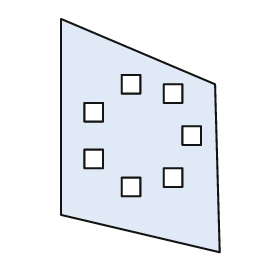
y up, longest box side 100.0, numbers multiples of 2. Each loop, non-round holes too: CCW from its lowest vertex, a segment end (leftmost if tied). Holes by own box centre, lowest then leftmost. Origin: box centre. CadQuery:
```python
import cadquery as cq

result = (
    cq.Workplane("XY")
    .moveTo(34.0, -50.0)
    .lineTo(32.0, 22.0)
    .lineTo(-34.0, 50.0)
    .lineTo(-34.0, -34.0)
    .close()
    .moveTo(-8.0, -26.0)
    .lineTo(0.0, -26.0)
    .lineTo(0.0, -18.0)
    .lineTo(-8.0, -18.0)
    .close()
    .moveTo(10.0, -22.0)
    .lineTo(18.0, -22.0)
    .lineTo(18.0, -14.0)
    .lineTo(10.0, -14.0)
    .close()
    .moveTo(-24.0, -14.0)
    .lineTo(-16.0, -14.0)
    .lineTo(-16.0, -6.0)
    .lineTo(-24.0, -6.0)
    .close()
    .moveTo(18.0, -4.0)
    .lineTo(26.0, -4.0)
    .lineTo(26.0, 4.0)
    .lineTo(18.0, 4.0)
    .close()
    .moveTo(-24.0, 6.0)
    .lineTo(-16.0, 6.0)
    .lineTo(-16.0, 14.0)
    .lineTo(-24.0, 14.0)
    .close()
    .moveTo(10.0, 14.0)
    .lineTo(18.0, 14.0)
    .lineTo(18.0, 22.0)
    .lineTo(10.0, 22.0)
    .close()
    .moveTo(-8.0, 18.0)
    .lineTo(0.0, 18.0)
    .lineTo(0.0, 26.0)
    .lineTo(-8.0, 26.0)
    .close()
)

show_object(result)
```